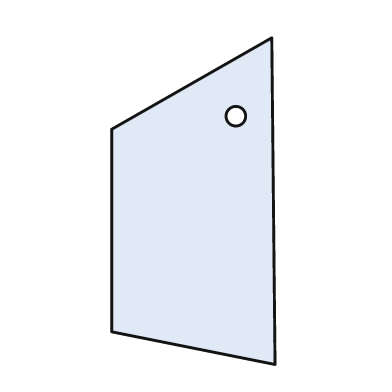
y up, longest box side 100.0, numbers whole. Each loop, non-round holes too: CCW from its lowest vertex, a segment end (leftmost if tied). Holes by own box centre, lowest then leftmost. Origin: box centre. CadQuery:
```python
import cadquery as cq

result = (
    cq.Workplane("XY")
    .moveTo(25.0, -50.0)
    .lineTo(24.0, 50.0)
    .lineTo(-25.0, 22.0)
    .lineTo(-25.0, -40.0)
    .close()
    .moveTo(13.0, 26.0)
    .circle(3.0)
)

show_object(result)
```